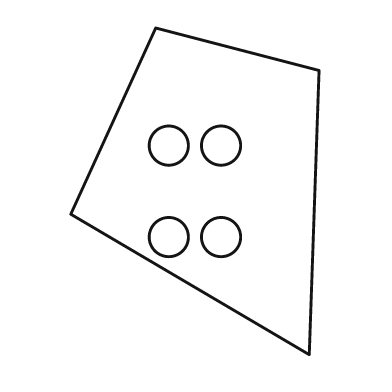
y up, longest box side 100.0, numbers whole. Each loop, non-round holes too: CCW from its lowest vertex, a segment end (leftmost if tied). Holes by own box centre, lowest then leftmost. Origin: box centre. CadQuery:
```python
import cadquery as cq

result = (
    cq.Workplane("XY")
    .moveTo(35.0, -50.0)
    .lineTo(38.0, 37.0)
    .lineTo(-12.0, 50.0)
    .lineTo(-38.0, -7.0)
    .close()
    .moveTo(-8.0, -14.0)
    .circle(6.0)
    .moveTo(8.0, -14.0)
    .circle(6.0)
    .moveTo(-8.0, 14.0)
    .circle(6.0)
    .moveTo(8.0, 14.0)
    .circle(6.0)
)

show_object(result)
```